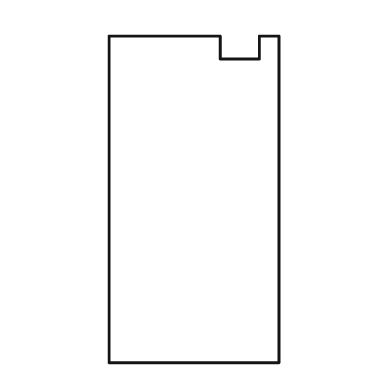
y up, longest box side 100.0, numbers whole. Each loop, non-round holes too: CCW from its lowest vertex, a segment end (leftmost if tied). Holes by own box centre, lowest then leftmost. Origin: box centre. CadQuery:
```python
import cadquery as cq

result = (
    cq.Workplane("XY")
    .moveTo(-26.0, -50.0)
    .lineTo(26.0, -50.0)
    .lineTo(26.0, 50.0)
    .lineTo(20.0, 50.0)
    .lineTo(20.0, 43.0)
    .lineTo(8.0, 43.0)
    .lineTo(8.0, 50.0)
    .lineTo(-26.0, 50.0)
    .close()
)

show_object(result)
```